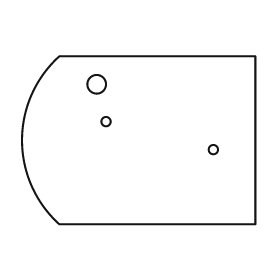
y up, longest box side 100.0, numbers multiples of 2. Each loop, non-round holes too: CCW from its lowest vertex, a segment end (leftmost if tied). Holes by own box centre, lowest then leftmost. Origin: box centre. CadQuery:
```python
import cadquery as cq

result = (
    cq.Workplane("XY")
    .moveTo(-34.0, -36.0)
    .lineTo(50.0, -36.0)
    .lineTo(50.0, 36.0)
    .lineTo(-34.0, 36.0)
    .threePointArc((-50.0, 0.0), (-34.0, -36.0))
    .close()
    .moveTo(32.0, -4.0)
    .circle(2.0)
    .moveTo(-14.0, 8.0)
    .circle(2.0)
    .moveTo(-18.0, 24.0)
    .circle(4.0)
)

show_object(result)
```